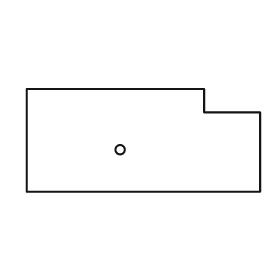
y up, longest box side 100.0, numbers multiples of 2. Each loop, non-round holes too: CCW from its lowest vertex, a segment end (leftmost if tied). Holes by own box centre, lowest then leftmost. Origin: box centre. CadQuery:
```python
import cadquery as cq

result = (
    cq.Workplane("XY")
    .moveTo(-50.0, -22.0)
    .lineTo(50.0, -22.0)
    .lineTo(50.0, 12.0)
    .lineTo(26.0, 12.0)
    .lineTo(26.0, 22.0)
    .lineTo(-50.0, 22.0)
    .close()
    .moveTo(-10.0, -4.0)
    .circle(2.0)
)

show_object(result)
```